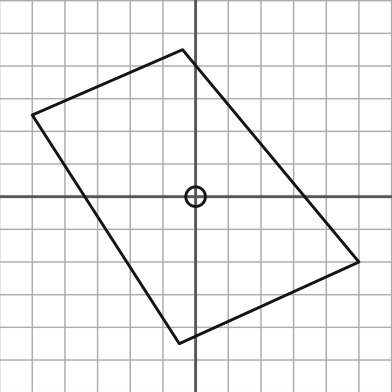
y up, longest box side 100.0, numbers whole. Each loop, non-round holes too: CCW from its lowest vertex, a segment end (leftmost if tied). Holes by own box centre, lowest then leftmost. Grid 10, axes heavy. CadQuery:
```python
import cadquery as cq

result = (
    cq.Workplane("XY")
    .moveTo(-5.0, -45.0)
    .lineTo(50.0, -20.0)
    .lineTo(-4.0, 45.0)
    .lineTo(-50.0, 25.0)
    .close()
    .moveTo(0.0, 0.0)
    .circle(3.0)
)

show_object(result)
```